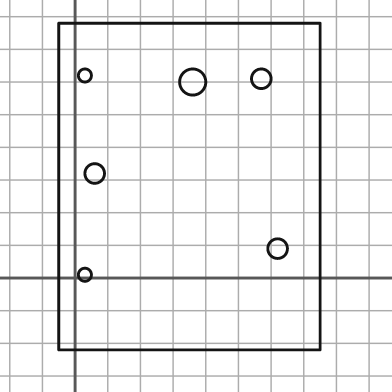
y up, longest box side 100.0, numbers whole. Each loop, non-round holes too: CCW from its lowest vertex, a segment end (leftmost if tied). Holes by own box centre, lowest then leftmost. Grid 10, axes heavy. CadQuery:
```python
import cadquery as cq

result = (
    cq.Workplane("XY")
    .moveTo(-5.0, -22.0)
    .lineTo(75.0, -22.0)
    .lineTo(75.0, 78.0)
    .lineTo(-5.0, 78.0)
    .close()
    .moveTo(3.0, 1.0)
    .circle(2.0)
    .moveTo(62.0, 9.0)
    .circle(3.0)
    .moveTo(6.0, 32.0)
    .circle(3.0)
    .moveTo(36.0, 60.0)
    .circle(4.0)
    .moveTo(57.0, 61.0)
    .circle(3.0)
    .moveTo(3.0, 62.0)
    .circle(2.0)
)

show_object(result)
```